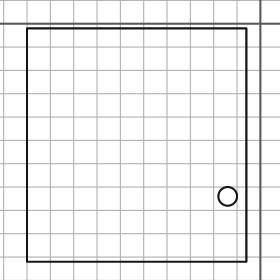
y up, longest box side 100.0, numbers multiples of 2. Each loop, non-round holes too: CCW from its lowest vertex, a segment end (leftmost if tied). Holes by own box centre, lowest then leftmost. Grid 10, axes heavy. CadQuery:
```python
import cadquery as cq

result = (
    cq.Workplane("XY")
    .moveTo(-100.0, -102.0)
    .lineTo(-6.0, -102.0)
    .lineTo(-6.0, -2.0)
    .lineTo(-100.0, -2.0)
    .close()
    .moveTo(-14.0, -74.0)
    .circle(4.0)
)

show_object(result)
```